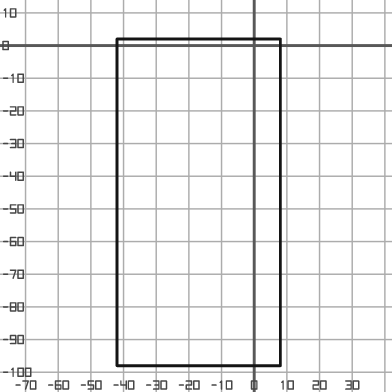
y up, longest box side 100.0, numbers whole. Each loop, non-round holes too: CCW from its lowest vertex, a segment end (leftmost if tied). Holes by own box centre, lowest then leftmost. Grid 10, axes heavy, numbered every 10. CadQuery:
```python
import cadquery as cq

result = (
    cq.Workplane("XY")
    .moveTo(-42.0, -98.0)
    .lineTo(8.0, -98.0)
    .lineTo(8.0, 2.0)
    .lineTo(-42.0, 2.0)
    .close()
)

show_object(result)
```